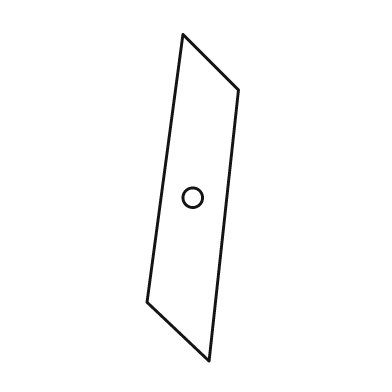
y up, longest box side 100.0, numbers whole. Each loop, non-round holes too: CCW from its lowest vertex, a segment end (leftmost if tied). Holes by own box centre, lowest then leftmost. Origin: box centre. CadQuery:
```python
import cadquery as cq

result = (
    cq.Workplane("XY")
    .moveTo(5.0, -50.0)
    .lineTo(14.0, 33.0)
    .lineTo(-3.0, 50.0)
    .lineTo(-14.0, -32.0)
    .close()
    .moveTo(0.0, 0.0)
    .circle(3.0)
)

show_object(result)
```